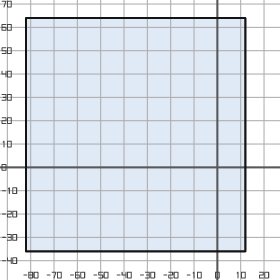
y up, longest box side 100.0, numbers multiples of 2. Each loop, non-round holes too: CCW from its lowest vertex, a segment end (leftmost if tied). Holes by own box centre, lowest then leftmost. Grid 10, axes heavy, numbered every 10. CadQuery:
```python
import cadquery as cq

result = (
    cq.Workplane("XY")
    .moveTo(-82.0, -36.0)
    .lineTo(12.0, -36.0)
    .lineTo(12.0, 64.0)
    .lineTo(-82.0, 64.0)
    .close()
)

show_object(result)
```